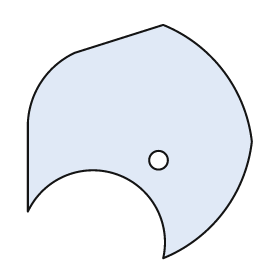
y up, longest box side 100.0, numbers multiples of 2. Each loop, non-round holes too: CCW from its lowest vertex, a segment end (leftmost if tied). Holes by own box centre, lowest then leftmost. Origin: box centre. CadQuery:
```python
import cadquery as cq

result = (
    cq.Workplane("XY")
    .moveTo(10.0, -50.0)
    .threePointArc((36.0, -30.0), (48.0, 0.0))
    .threePointArc((36.0, 30.0), (10.0, 50.0))
    .lineTo(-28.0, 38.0)
    .threePointArc((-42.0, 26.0), (-48.0, 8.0))
    .lineTo(-48.0, -30.0)
    .threePointArc((-10.0, -14.0), (10.0, -50.0))
    .close()
    .moveTo(8.0, -8.0)
    .circle(4.0)
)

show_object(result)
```